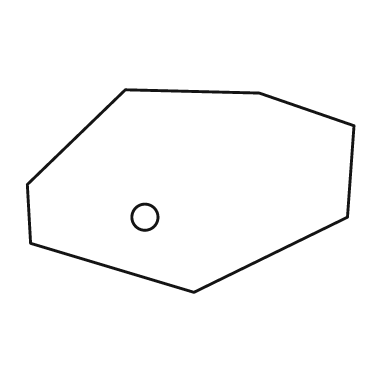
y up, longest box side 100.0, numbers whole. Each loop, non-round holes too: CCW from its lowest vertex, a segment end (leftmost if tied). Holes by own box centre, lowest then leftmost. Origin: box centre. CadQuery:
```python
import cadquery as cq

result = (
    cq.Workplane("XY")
    .moveTo(1.0, -31.0)
    .lineTo(48.0, -8.0)
    .lineTo(50.0, 20.0)
    .lineTo(21.0, 30.0)
    .lineTo(-20.0, 31.0)
    .lineTo(-50.0, 2.0)
    .lineTo(-49.0, -16.0)
    .close()
    .moveTo(-14.0, -8.0)
    .circle(4.0)
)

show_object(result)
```